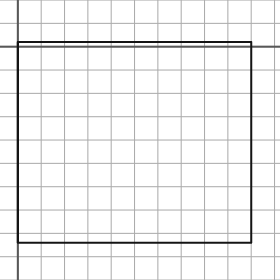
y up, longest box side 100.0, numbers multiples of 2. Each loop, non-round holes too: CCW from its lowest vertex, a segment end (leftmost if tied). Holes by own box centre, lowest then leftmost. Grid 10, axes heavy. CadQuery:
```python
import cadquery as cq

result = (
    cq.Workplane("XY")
    .moveTo(0.0, -84.0)
    .lineTo(100.0, -84.0)
    .lineTo(100.0, 2.0)
    .lineTo(0.0, 2.0)
    .close()
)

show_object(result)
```